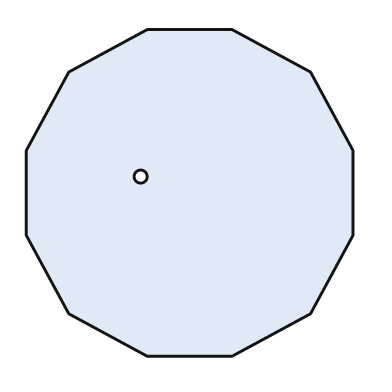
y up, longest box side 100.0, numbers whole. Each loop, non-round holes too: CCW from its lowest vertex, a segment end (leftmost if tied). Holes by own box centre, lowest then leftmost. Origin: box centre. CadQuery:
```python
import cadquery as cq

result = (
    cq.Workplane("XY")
    .moveTo(-13.0, -50.0)
    .lineTo(13.0, -50.0)
    .lineTo(37.0, -37.0)
    .lineTo(50.0, -13.0)
    .lineTo(50.0, 13.0)
    .lineTo(37.0, 37.0)
    .lineTo(13.0, 50.0)
    .lineTo(-13.0, 50.0)
    .lineTo(-37.0, 37.0)
    .lineTo(-50.0, 13.0)
    .lineTo(-50.0, -13.0)
    .lineTo(-37.0, -37.0)
    .close()
    .moveTo(-15.0, 5.0)
    .circle(2.0)
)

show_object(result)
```